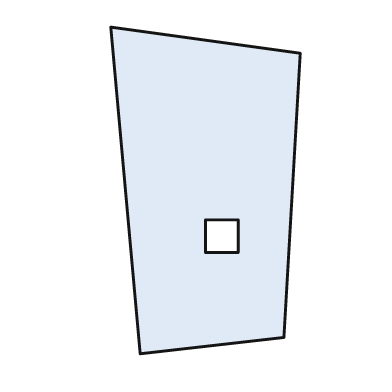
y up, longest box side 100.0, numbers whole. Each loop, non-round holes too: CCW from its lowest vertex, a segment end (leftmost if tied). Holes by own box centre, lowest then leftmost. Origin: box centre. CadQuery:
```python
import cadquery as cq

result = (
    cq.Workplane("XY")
    .moveTo(-20.0, -50.0)
    .lineTo(24.0, -45.0)
    .lineTo(29.0, 42.0)
    .lineTo(-29.0, 50.0)
    .close()
    .moveTo(0.0, -19.0)
    .lineTo(10.0, -19.0)
    .lineTo(10.0, -9.0)
    .lineTo(0.0, -9.0)
    .close()
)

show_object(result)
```